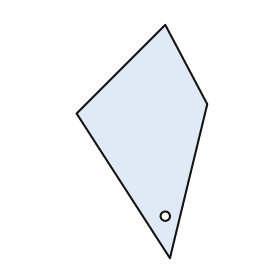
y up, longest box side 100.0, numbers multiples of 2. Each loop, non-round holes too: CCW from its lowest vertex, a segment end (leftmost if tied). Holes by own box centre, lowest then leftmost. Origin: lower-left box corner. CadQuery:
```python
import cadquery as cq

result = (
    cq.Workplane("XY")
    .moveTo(40.0, 0.0)
    .lineTo(56.0, 66.0)
    .lineTo(38.0, 100.0)
    .lineTo(0.0, 62.0)
    .close()
    .moveTo(38.0, 18.0)
    .circle(2.0)
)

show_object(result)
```